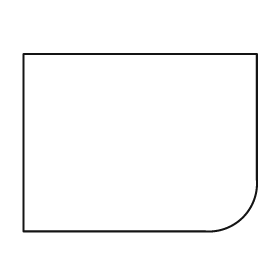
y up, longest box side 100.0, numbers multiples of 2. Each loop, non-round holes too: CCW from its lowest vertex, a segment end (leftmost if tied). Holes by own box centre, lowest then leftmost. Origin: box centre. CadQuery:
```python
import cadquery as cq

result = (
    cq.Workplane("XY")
    .moveTo(-50.0, -38.0)
    .lineTo(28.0, -38.0)
    .threePointArc((44.0, -32.0), (50.0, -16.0))
    .lineTo(50.0, 38.0)
    .lineTo(-50.0, 38.0)
    .close()
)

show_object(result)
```